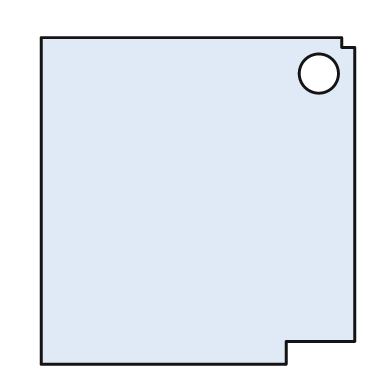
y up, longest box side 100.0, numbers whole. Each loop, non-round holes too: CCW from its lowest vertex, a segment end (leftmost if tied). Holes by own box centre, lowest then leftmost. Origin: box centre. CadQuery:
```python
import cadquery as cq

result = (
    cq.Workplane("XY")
    .moveTo(-48.0, -50.0)
    .lineTo(27.0, -50.0)
    .lineTo(27.0, -43.0)
    .lineTo(48.0, -43.0)
    .lineTo(48.0, 47.0)
    .lineTo(44.0, 47.0)
    .lineTo(44.0, 50.0)
    .lineTo(-48.0, 50.0)
    .close()
    .moveTo(37.0, 39.0)
    .circle(6.0)
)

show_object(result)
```